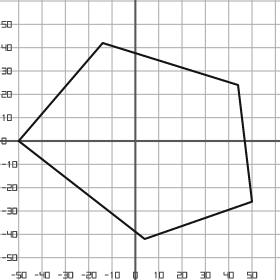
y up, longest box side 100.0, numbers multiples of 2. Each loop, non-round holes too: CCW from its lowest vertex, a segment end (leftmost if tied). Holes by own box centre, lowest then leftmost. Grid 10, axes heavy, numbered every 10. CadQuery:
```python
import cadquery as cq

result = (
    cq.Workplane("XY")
    .moveTo(4.0, -42.0)
    .lineTo(50.0, -26.0)
    .lineTo(44.0, 24.0)
    .lineTo(-14.0, 42.0)
    .lineTo(-50.0, 0.0)
    .close()
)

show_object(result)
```